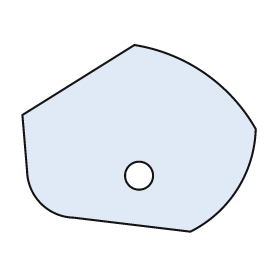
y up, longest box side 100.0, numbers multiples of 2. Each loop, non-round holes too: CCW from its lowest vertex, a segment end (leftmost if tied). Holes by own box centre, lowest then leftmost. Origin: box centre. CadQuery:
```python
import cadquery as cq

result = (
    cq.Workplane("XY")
    .moveTo(22.0, -40.0)
    .threePointArc((42.0, -22.0), (50.0, 4.0))
    .threePointArc((28.0, 28.0), (-2.0, 40.0))
    .lineTo(-50.0, 10.0)
    .lineTo(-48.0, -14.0)
    .threePointArc((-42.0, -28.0), (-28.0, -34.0))
    .close()
    .moveTo(0.0, -16.0)
    .circle(6.0)
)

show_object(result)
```